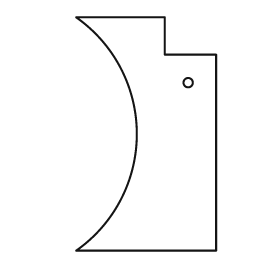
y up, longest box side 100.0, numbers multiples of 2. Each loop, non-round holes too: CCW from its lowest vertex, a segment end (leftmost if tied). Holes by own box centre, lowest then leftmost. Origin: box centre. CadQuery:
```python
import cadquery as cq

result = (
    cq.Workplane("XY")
    .moveTo(-30.0, -50.0)
    .lineTo(30.0, -50.0)
    .lineTo(30.0, 34.0)
    .lineTo(8.0, 34.0)
    .lineTo(8.0, 50.0)
    .lineTo(-30.0, 50.0)
    .threePointArc((-4.0, 0.0), (-30.0, -50.0))
    .close()
    .moveTo(18.0, 22.0)
    .circle(2.0)
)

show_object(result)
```